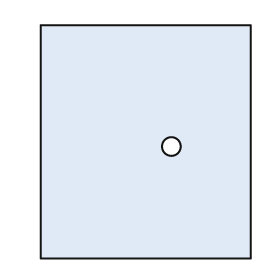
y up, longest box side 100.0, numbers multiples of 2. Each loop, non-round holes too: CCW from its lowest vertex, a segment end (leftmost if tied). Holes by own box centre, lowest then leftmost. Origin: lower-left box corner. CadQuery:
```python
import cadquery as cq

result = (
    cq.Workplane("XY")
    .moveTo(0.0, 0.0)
    .lineTo(90.0, 0.0)
    .lineTo(90.0, 100.0)
    .lineTo(0.0, 100.0)
    .close()
    .moveTo(56.0, 48.0)
    .circle(4.0)
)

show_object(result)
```